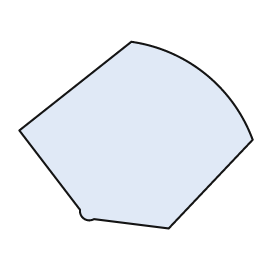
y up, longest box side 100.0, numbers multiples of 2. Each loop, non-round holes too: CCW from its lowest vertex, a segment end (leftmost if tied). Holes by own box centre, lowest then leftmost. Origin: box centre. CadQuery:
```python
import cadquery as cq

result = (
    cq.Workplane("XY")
    .moveTo(14.0, -40.0)
    .lineTo(50.0, -2.0)
    .threePointArc((30.0, 26.0), (-2.0, 40.0))
    .lineTo(-50.0, 2.0)
    .lineTo(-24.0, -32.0)
    .threePointArc((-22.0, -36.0), (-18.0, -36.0))
    .close()
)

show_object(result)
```